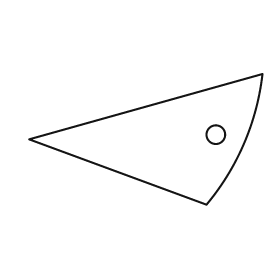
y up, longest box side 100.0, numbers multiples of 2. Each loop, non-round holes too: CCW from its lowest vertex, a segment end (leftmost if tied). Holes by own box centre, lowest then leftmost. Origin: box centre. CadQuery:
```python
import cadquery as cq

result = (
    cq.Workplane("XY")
    .moveTo(26.0, -28.0)
    .threePointArc((42.0, -2.0), (50.0, 28.0))
    .lineTo(-50.0, 0.0)
    .close()
    .moveTo(30.0, 2.0)
    .circle(4.0)
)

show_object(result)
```